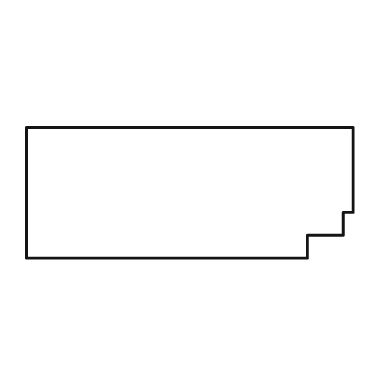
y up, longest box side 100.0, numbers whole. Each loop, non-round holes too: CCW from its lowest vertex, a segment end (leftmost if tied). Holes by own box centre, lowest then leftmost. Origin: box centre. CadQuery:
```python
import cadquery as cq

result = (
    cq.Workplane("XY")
    .moveTo(-50.0, -20.0)
    .lineTo(36.0, -20.0)
    .lineTo(36.0, -13.0)
    .lineTo(47.0, -13.0)
    .lineTo(47.0, -6.0)
    .lineTo(50.0, -6.0)
    .lineTo(50.0, 20.0)
    .lineTo(-50.0, 20.0)
    .close()
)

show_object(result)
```